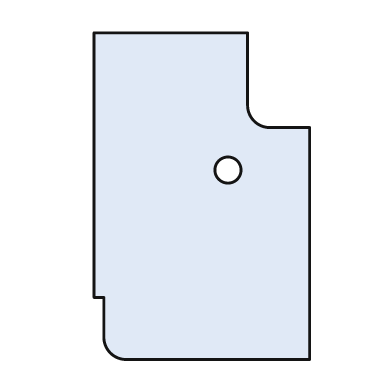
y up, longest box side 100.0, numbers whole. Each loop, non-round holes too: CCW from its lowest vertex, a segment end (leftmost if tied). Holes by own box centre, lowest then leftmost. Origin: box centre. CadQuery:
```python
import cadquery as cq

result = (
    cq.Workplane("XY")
    .moveTo(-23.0, -50.0)
    .lineTo(33.0, -50.0)
    .lineTo(33.0, 21.0)
    .lineTo(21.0, 21.0)
    .threePointArc((16.0, 23.0), (14.0, 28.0))
    .lineTo(14.0, 50.0)
    .lineTo(-33.0, 50.0)
    .lineTo(-33.0, -31.0)
    .lineTo(-30.0, -31.0)
    .lineTo(-30.0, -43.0)
    .threePointArc((-28.0, -48.0), (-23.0, -50.0))
    .close()
    .moveTo(8.0, 8.0)
    .circle(4.0)
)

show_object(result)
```